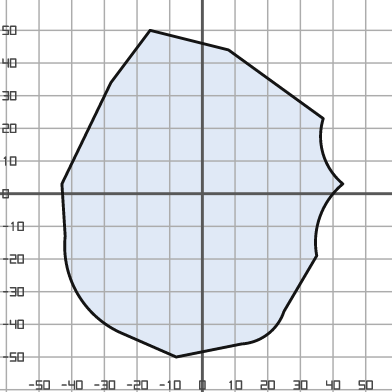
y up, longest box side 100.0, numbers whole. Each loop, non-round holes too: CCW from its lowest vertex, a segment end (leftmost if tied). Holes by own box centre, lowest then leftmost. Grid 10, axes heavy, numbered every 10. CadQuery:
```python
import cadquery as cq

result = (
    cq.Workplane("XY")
    .moveTo(-8.0, -50.0)
    .lineTo(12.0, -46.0)
    .threePointArc((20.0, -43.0), (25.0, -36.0))
    .lineTo(35.0, -19.0)
    .threePointArc((36.0, -7.0), (43.0, 3.0))
    .threePointArc((37.0, 12.0), (37.0, 23.0))
    .lineTo(8.0, 44.0)
    .lineTo(-16.0, 50.0)
    .lineTo(-28.0, 34.0)
    .lineTo(-43.0, 3.0)
    .lineTo(-42.0, -13.0)
    .threePointArc((-38.0, -31.0), (-24.0, -43.0))
    .close()
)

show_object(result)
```